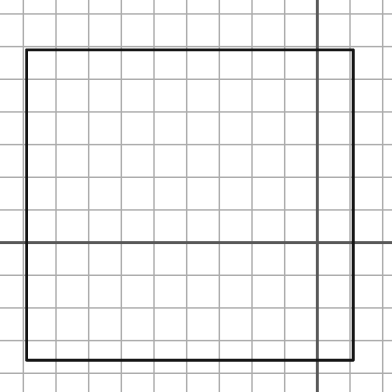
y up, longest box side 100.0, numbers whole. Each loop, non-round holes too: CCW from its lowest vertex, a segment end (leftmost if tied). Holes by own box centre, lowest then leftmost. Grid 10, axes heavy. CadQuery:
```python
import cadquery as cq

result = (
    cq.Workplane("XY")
    .moveTo(-89.0, -36.0)
    .lineTo(11.0, -36.0)
    .lineTo(11.0, 59.0)
    .lineTo(-89.0, 59.0)
    .close()
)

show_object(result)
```